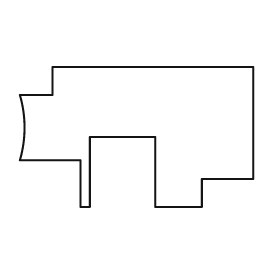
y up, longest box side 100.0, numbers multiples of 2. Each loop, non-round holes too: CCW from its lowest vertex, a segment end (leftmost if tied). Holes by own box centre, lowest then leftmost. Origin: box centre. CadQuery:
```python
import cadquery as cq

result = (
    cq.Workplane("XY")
    .moveTo(-24.0, -30.0)
    .lineTo(-20.0, -30.0)
    .lineTo(-20.0, 0.0)
    .lineTo(8.0, 0.0)
    .lineTo(8.0, -30.0)
    .lineTo(28.0, -30.0)
    .lineTo(28.0, -18.0)
    .lineTo(50.0, -18.0)
    .lineTo(50.0, 30.0)
    .lineTo(-36.0, 30.0)
    .lineTo(-36.0, 18.0)
    .lineTo(-50.0, 18.0)
    .threePointArc((-48.0, 4.0), (-50.0, -10.0))
    .lineTo(-24.0, -10.0)
    .close()
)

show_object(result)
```